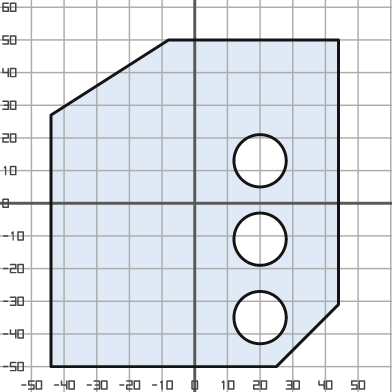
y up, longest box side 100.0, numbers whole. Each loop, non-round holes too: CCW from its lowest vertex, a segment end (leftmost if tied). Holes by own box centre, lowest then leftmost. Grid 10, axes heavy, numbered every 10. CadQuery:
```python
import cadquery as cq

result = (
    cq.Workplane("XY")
    .moveTo(-44.0, -50.0)
    .lineTo(25.0, -50.0)
    .lineTo(44.0, -31.0)
    .lineTo(44.0, 50.0)
    .lineTo(-8.0, 50.0)
    .lineTo(-44.0, 27.0)
    .close()
    .moveTo(20.0, -35.0)
    .circle(8.0)
    .moveTo(20.0, -11.0)
    .circle(8.0)
    .moveTo(20.0, 13.0)
    .circle(8.0)
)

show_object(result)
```